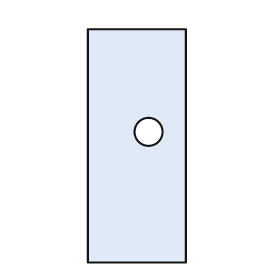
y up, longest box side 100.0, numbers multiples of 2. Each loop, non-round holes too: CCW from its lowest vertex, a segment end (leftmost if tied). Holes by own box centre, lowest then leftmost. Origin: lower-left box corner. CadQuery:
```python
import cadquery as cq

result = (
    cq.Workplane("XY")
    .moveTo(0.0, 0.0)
    .lineTo(42.0, 0.0)
    .lineTo(42.0, 100.0)
    .lineTo(0.0, 100.0)
    .close()
    .moveTo(26.0, 56.0)
    .circle(6.0)
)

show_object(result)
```